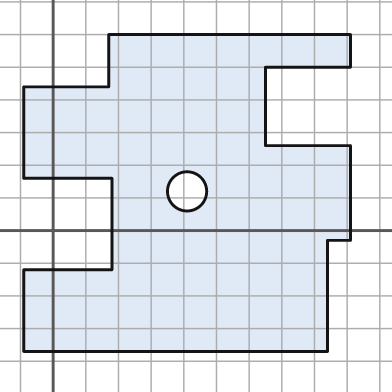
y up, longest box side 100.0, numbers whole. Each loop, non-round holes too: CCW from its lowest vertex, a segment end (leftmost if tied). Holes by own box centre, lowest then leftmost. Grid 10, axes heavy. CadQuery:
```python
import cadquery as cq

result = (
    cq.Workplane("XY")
    .moveTo(-9.0, -37.0)
    .lineTo(84.0, -37.0)
    .lineTo(84.0, -3.0)
    .lineTo(91.0, -3.0)
    .lineTo(91.0, 26.0)
    .lineTo(65.0, 26.0)
    .lineTo(65.0, 50.0)
    .lineTo(91.0, 50.0)
    .lineTo(91.0, 60.0)
    .lineTo(17.0, 60.0)
    .lineTo(17.0, 44.0)
    .lineTo(-9.0, 44.0)
    .lineTo(-9.0, 16.0)
    .lineTo(18.0, 16.0)
    .lineTo(18.0, -12.0)
    .lineTo(-9.0, -12.0)
    .close()
    .moveTo(41.0, 12.0)
    .circle(6.0)
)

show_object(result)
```